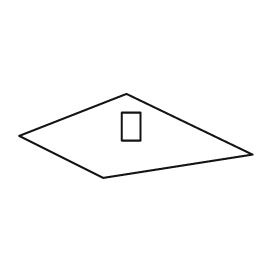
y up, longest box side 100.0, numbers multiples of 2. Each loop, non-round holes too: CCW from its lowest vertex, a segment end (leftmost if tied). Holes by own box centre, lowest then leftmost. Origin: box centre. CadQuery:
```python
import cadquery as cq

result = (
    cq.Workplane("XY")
    .moveTo(-14.0, -18.0)
    .lineTo(50.0, -8.0)
    .lineTo(-4.0, 18.0)
    .lineTo(-50.0, 0.0)
    .close()
    .moveTo(-6.0, -2.0)
    .lineTo(2.0, -2.0)
    .lineTo(2.0, 10.0)
    .lineTo(-6.0, 10.0)
    .close()
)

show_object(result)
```